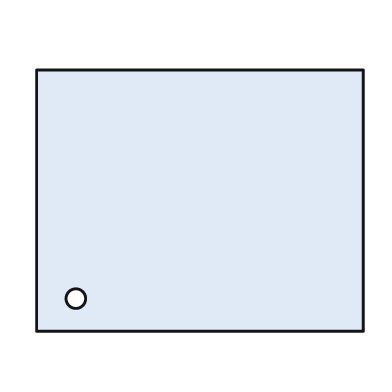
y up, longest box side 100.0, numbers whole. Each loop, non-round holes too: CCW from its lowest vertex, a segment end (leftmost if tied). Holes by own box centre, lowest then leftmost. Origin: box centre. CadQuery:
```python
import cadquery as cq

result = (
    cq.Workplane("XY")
    .moveTo(-50.0, -40.0)
    .lineTo(50.0, -40.0)
    .lineTo(50.0, 40.0)
    .lineTo(-50.0, 40.0)
    .close()
    .moveTo(-38.0, -30.0)
    .circle(3.0)
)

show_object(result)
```